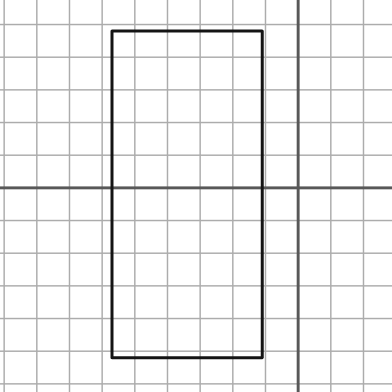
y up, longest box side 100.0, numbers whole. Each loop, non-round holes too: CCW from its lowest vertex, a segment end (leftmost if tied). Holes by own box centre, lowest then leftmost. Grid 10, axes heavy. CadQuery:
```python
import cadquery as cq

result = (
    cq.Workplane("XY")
    .moveTo(-57.0, -52.0)
    .lineTo(-11.0, -52.0)
    .lineTo(-11.0, 48.0)
    .lineTo(-57.0, 48.0)
    .close()
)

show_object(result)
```